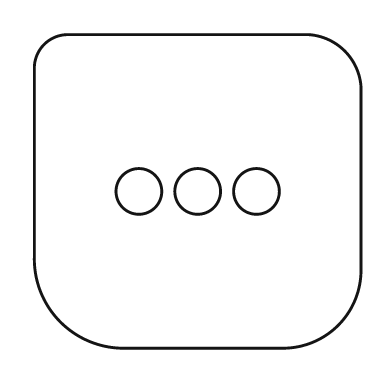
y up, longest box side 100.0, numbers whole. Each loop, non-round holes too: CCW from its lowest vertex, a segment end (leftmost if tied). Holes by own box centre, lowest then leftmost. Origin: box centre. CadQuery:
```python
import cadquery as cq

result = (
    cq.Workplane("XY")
    .moveTo(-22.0, -48.0)
    .lineTo(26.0, -48.0)
    .threePointArc((43.0, -41.0), (50.0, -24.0))
    .lineTo(50.0, 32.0)
    .threePointArc((45.0, 43.0), (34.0, 48.0))
    .lineTo(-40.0, 48.0)
    .threePointArc((-47.0, 45.0), (-50.0, 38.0))
    .lineTo(-50.0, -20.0)
    .threePointArc((-42.0, -40.0), (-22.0, -48.0))
    .close()
    .moveTo(-18.0, 0.0)
    .circle(7.0)
    .moveTo(0.0, 0.0)
    .circle(7.0)
    .moveTo(18.0, 0.0)
    .circle(7.0)
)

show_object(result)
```